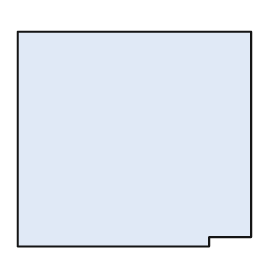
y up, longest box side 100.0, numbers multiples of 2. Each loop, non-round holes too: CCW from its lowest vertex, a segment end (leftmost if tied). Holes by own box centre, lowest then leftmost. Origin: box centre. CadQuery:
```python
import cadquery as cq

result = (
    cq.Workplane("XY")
    .moveTo(-50.0, -46.0)
    .lineTo(32.0, -46.0)
    .lineTo(32.0, -42.0)
    .lineTo(50.0, -42.0)
    .lineTo(50.0, 46.0)
    .lineTo(-50.0, 46.0)
    .close()
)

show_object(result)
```